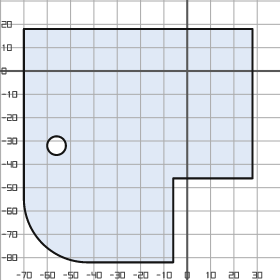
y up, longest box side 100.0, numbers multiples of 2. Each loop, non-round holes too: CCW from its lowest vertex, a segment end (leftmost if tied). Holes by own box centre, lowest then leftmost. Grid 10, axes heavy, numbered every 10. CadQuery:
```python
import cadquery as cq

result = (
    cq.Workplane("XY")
    .moveTo(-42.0, -82.0)
    .lineTo(-6.0, -82.0)
    .lineTo(-6.0, -46.0)
    .lineTo(28.0, -46.0)
    .lineTo(28.0, 18.0)
    .lineTo(-70.0, 18.0)
    .lineTo(-70.0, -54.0)
    .threePointArc((-62.0, -74.0), (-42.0, -82.0))
    .close()
    .moveTo(-56.0, -32.0)
    .circle(4.0)
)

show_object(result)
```